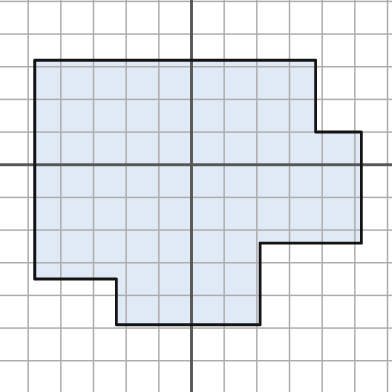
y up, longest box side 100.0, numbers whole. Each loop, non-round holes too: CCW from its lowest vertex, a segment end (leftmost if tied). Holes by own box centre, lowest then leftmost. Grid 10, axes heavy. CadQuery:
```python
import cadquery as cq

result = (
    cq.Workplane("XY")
    .moveTo(-23.0, -49.0)
    .lineTo(21.0, -49.0)
    .lineTo(21.0, -24.0)
    .lineTo(52.0, -24.0)
    .lineTo(52.0, 10.0)
    .lineTo(38.0, 10.0)
    .lineTo(38.0, 32.0)
    .lineTo(-48.0, 32.0)
    .lineTo(-48.0, -35.0)
    .lineTo(-23.0, -35.0)
    .close()
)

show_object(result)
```